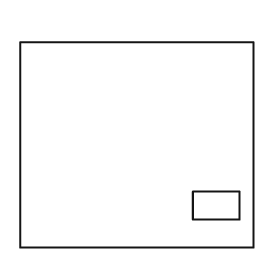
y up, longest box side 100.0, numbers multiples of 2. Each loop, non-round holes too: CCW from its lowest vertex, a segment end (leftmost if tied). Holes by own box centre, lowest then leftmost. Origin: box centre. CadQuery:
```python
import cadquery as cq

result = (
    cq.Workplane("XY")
    .moveTo(-50.0, -44.0)
    .lineTo(50.0, -44.0)
    .lineTo(50.0, 44.0)
    .lineTo(-50.0, 44.0)
    .close()
    .moveTo(24.0, -32.0)
    .lineTo(44.0, -32.0)
    .lineTo(44.0, -20.0)
    .lineTo(24.0, -20.0)
    .close()
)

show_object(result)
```